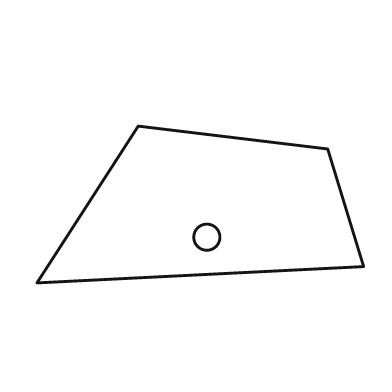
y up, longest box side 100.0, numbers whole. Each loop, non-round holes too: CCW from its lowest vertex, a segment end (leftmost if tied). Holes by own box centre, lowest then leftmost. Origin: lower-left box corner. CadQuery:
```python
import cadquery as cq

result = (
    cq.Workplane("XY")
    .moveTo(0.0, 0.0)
    .lineTo(100.0, 5.0)
    .lineTo(89.0, 41.0)
    .lineTo(31.0, 48.0)
    .close()
    .moveTo(52.0, 14.0)
    .circle(4.0)
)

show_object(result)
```